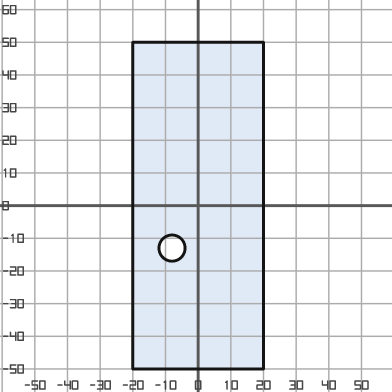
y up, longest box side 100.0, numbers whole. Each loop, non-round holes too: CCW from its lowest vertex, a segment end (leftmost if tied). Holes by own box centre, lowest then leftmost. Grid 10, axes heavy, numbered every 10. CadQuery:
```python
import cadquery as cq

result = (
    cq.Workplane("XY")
    .moveTo(-20.0, -50.0)
    .lineTo(20.0, -50.0)
    .lineTo(20.0, 50.0)
    .lineTo(-20.0, 50.0)
    .close()
    .moveTo(-8.0, -13.0)
    .circle(4.0)
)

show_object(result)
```